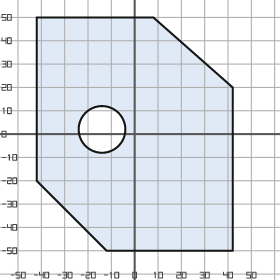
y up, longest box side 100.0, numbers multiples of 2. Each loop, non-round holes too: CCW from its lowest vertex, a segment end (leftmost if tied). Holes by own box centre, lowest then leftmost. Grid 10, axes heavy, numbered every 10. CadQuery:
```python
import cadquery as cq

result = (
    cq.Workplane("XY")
    .moveTo(-12.0, -50.0)
    .lineTo(42.0, -50.0)
    .lineTo(42.0, 20.0)
    .lineTo(8.0, 50.0)
    .lineTo(-42.0, 50.0)
    .lineTo(-42.0, -20.0)
    .close()
    .moveTo(-14.0, 2.0)
    .circle(10.0)
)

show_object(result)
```